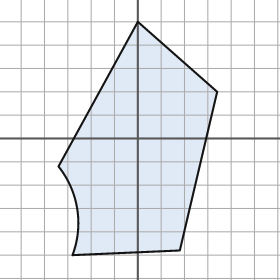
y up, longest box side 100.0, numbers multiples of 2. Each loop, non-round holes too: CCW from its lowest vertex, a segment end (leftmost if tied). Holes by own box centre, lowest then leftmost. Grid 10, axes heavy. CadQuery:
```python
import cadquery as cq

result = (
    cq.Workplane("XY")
    .moveTo(-28.0, -50.0)
    .lineTo(18.0, -48.0)
    .lineTo(34.0, 20.0)
    .lineTo(0.0, 50.0)
    .lineTo(-34.0, -12.0)
    .threePointArc((-26.0, -30.0), (-28.0, -50.0))
    .close()
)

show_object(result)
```